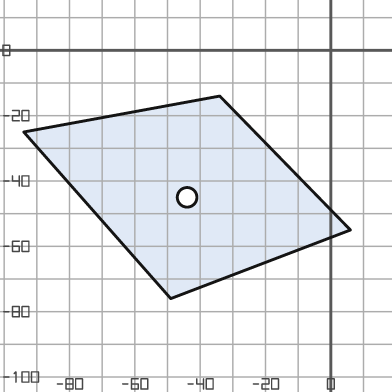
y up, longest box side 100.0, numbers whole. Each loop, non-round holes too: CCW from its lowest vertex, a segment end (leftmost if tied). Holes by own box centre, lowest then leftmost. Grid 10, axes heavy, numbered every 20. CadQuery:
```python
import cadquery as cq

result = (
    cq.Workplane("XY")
    .moveTo(-49.0, -76.0)
    .lineTo(6.0, -55.0)
    .lineTo(-34.0, -14.0)
    .lineTo(-94.0, -25.0)
    .close()
    .moveTo(-44.0, -45.0)
    .circle(3.0)
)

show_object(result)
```